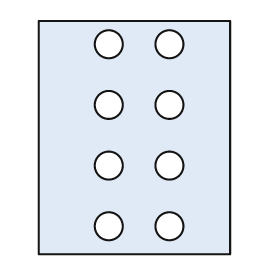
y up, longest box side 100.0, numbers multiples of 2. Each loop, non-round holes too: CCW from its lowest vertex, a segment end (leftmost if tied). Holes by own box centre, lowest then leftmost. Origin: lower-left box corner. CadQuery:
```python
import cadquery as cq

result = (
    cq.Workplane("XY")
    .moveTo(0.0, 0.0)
    .lineTo(82.0, 0.0)
    .lineTo(82.0, 100.0)
    .lineTo(0.0, 100.0)
    .close()
    .moveTo(30.0, 12.0)
    .circle(6.0)
    .moveTo(56.0, 12.0)
    .circle(6.0)
    .moveTo(30.0, 38.0)
    .circle(6.0)
    .moveTo(56.0, 38.0)
    .circle(6.0)
    .moveTo(30.0, 64.0)
    .circle(6.0)
    .moveTo(56.0, 64.0)
    .circle(6.0)
    .moveTo(30.0, 90.0)
    .circle(6.0)
    .moveTo(56.0, 90.0)
    .circle(6.0)
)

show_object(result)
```